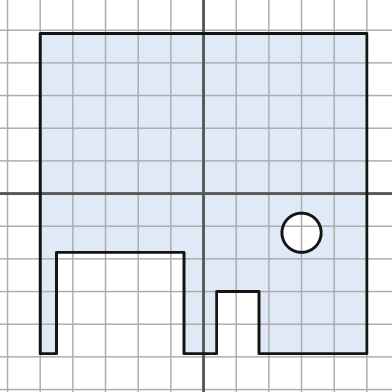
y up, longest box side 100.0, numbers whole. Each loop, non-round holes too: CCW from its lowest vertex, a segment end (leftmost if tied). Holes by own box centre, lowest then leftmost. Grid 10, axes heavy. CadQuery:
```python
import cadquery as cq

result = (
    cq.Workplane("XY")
    .moveTo(-50.0, -49.0)
    .lineTo(-45.0, -49.0)
    .lineTo(-45.0, -18.0)
    .lineTo(-6.0, -18.0)
    .lineTo(-6.0, -49.0)
    .lineTo(4.0, -49.0)
    .lineTo(4.0, -30.0)
    .lineTo(17.0, -30.0)
    .lineTo(17.0, -49.0)
    .lineTo(50.0, -49.0)
    .lineTo(50.0, 49.0)
    .lineTo(-50.0, 49.0)
    .close()
    .moveTo(30.0, -12.0)
    .circle(6.0)
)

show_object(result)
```